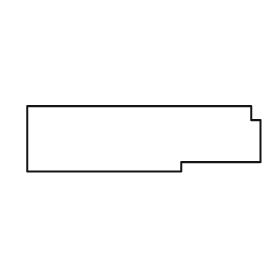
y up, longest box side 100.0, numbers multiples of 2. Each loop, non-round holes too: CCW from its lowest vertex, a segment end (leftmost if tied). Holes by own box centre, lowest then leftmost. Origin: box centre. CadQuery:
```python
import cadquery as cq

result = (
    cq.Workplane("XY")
    .moveTo(-50.0, -14.0)
    .lineTo(16.0, -14.0)
    .lineTo(16.0, -10.0)
    .lineTo(50.0, -10.0)
    .lineTo(50.0, 8.0)
    .lineTo(46.0, 8.0)
    .lineTo(46.0, 14.0)
    .lineTo(-50.0, 14.0)
    .close()
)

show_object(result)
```